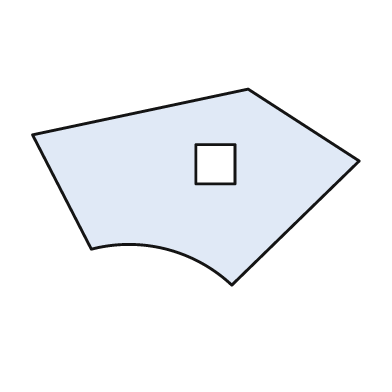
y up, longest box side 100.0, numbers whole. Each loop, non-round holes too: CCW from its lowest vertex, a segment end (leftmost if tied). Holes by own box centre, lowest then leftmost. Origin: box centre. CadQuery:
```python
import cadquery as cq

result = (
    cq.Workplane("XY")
    .moveTo(11.0, -30.0)
    .lineTo(50.0, 8.0)
    .lineTo(16.0, 30.0)
    .lineTo(-50.0, 16.0)
    .lineTo(-32.0, -19.0)
    .threePointArc((-9.0, -19.0), (11.0, -30.0))
    .close()
    .moveTo(0.0, 1.0)
    .lineTo(12.0, 1.0)
    .lineTo(12.0, 13.0)
    .lineTo(0.0, 13.0)
    .close()
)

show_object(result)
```